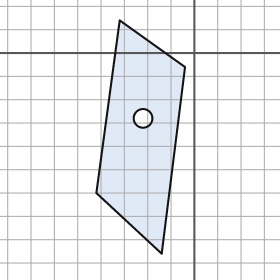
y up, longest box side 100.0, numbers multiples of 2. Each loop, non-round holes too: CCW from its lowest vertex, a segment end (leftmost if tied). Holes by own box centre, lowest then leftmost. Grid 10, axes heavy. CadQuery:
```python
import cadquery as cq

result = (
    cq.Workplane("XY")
    .moveTo(-14.0, -86.0)
    .lineTo(-4.0, -6.0)
    .lineTo(-32.0, 14.0)
    .lineTo(-42.0, -60.0)
    .close()
    .moveTo(-22.0, -28.0)
    .circle(4.0)
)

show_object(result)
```